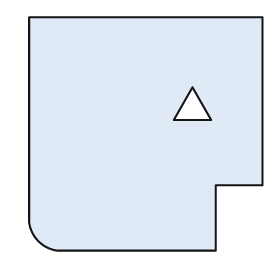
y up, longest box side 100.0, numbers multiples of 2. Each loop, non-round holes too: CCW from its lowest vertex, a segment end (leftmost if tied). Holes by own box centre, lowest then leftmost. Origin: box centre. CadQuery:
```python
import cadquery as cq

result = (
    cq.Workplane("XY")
    .moveTo(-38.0, -50.0)
    .lineTo(30.0, -50.0)
    .lineTo(30.0, -22.0)
    .lineTo(50.0, -22.0)
    .lineTo(50.0, 50.0)
    .lineTo(-50.0, 50.0)
    .lineTo(-50.0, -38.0)
    .threePointArc((-46.0, -46.0), (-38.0, -50.0))
    .close()
    .moveTo(12.0, 6.0)
    .lineTo(28.0, 6.0)
    .lineTo(20.0, 20.0)
    .close()
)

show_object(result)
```